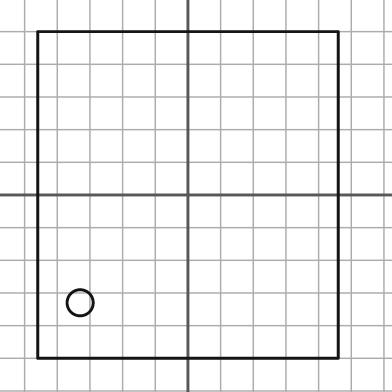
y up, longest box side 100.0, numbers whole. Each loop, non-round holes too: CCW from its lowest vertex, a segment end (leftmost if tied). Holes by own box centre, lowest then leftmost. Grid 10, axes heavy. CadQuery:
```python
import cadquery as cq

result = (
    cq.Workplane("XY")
    .moveTo(-46.0, -50.0)
    .lineTo(46.0, -50.0)
    .lineTo(46.0, 50.0)
    .lineTo(-46.0, 50.0)
    .close()
    .moveTo(-33.0, -33.0)
    .circle(4.0)
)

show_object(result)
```